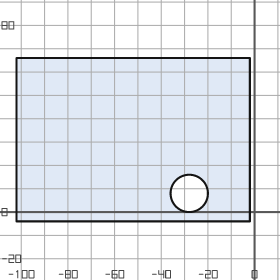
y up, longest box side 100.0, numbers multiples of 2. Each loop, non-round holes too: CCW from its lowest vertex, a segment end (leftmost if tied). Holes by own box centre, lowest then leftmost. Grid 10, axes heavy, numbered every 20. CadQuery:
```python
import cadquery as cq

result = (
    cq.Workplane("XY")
    .moveTo(-102.0, -4.0)
    .lineTo(-2.0, -4.0)
    .lineTo(-2.0, 66.0)
    .lineTo(-102.0, 66.0)
    .close()
    .moveTo(-28.0, 8.0)
    .circle(8.0)
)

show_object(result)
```